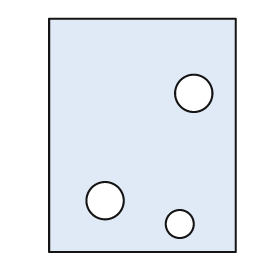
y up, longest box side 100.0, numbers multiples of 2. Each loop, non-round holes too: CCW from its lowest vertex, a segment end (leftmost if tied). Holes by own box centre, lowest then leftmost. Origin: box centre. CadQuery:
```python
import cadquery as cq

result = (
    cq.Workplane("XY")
    .moveTo(-40.0, -50.0)
    .lineTo(40.0, -50.0)
    .lineTo(40.0, 50.0)
    .lineTo(-40.0, 50.0)
    .close()
    .moveTo(16.0, -38.0)
    .circle(6.0)
    .moveTo(-16.0, -28.0)
    .circle(8.0)
    .moveTo(22.0, 18.0)
    .circle(8.0)
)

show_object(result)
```